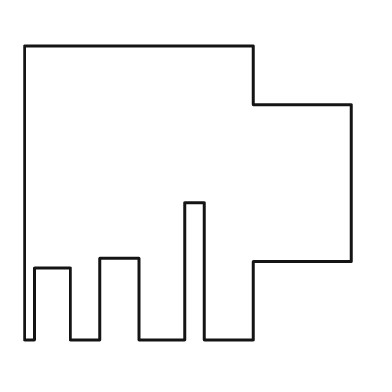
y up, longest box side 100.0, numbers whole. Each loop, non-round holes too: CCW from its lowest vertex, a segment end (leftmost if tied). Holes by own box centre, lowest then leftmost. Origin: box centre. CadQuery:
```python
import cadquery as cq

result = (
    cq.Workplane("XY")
    .moveTo(-50.0, -45.0)
    .lineTo(-47.0, -45.0)
    .lineTo(-47.0, -23.0)
    .lineTo(-36.0, -23.0)
    .lineTo(-36.0, -45.0)
    .lineTo(-27.0, -45.0)
    .lineTo(-27.0, -20.0)
    .lineTo(-15.0, -20.0)
    .lineTo(-15.0, -45.0)
    .lineTo(-1.0, -45.0)
    .lineTo(-1.0, -3.0)
    .lineTo(5.0, -3.0)
    .lineTo(5.0, -45.0)
    .lineTo(20.0, -45.0)
    .lineTo(20.0, -21.0)
    .lineTo(50.0, -21.0)
    .lineTo(50.0, 27.0)
    .lineTo(20.0, 27.0)
    .lineTo(20.0, 45.0)
    .lineTo(-50.0, 45.0)
    .close()
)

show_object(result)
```